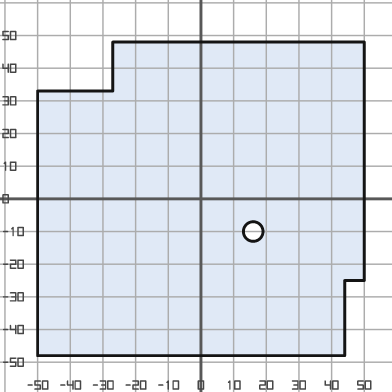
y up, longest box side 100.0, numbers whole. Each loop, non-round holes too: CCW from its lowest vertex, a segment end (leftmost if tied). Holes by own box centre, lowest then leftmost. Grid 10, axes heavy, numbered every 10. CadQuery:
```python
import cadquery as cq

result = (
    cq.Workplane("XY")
    .moveTo(-50.0, -48.0)
    .lineTo(44.0, -48.0)
    .lineTo(44.0, -25.0)
    .lineTo(50.0, -25.0)
    .lineTo(50.0, 48.0)
    .lineTo(-27.0, 48.0)
    .lineTo(-27.0, 33.0)
    .lineTo(-50.0, 33.0)
    .close()
    .moveTo(16.0, -10.0)
    .circle(3.0)
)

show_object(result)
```